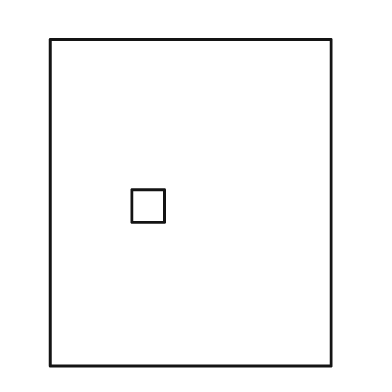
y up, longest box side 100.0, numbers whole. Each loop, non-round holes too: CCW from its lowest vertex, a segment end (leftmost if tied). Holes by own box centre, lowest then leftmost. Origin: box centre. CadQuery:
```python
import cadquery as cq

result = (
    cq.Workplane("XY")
    .moveTo(-43.0, -50.0)
    .lineTo(43.0, -50.0)
    .lineTo(43.0, 50.0)
    .lineTo(-43.0, 50.0)
    .close()
    .moveTo(-18.0, -6.0)
    .lineTo(-8.0, -6.0)
    .lineTo(-8.0, 4.0)
    .lineTo(-18.0, 4.0)
    .close()
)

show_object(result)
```